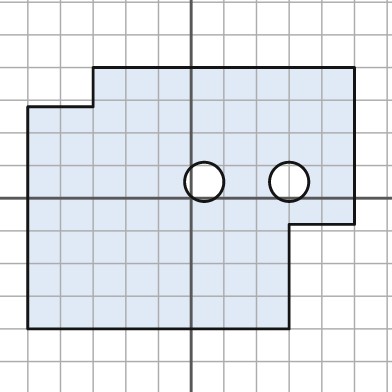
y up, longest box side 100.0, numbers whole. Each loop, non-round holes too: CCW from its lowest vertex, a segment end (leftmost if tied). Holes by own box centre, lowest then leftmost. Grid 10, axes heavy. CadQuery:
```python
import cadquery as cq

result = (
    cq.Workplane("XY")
    .moveTo(-50.0, -40.0)
    .lineTo(30.0, -40.0)
    .lineTo(30.0, -8.0)
    .lineTo(50.0, -8.0)
    .lineTo(50.0, 40.0)
    .lineTo(-30.0, 40.0)
    .lineTo(-30.0, 28.0)
    .lineTo(-50.0, 28.0)
    .close()
    .moveTo(4.0, 5.0)
    .circle(6.0)
    .moveTo(30.0, 5.0)
    .circle(6.0)
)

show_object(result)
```